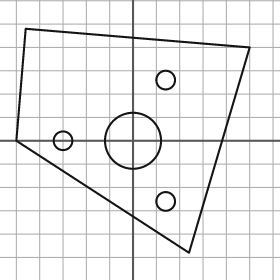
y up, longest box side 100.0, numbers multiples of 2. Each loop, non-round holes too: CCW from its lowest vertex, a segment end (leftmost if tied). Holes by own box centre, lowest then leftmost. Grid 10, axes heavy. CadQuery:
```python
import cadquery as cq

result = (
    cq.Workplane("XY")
    .moveTo(24.0, -48.0)
    .lineTo(50.0, 40.0)
    .lineTo(-46.0, 48.0)
    .lineTo(-50.0, 0.0)
    .close()
    .moveTo(14.0, -26.0)
    .circle(4.0)
    .moveTo(-30.0, 0.0)
    .circle(4.0)
    .moveTo(0.0, 0.0)
    .circle(12.0)
    .moveTo(14.0, 26.0)
    .circle(4.0)
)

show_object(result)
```